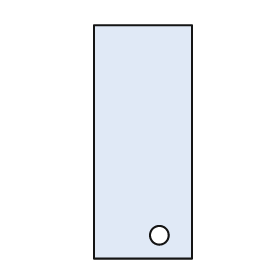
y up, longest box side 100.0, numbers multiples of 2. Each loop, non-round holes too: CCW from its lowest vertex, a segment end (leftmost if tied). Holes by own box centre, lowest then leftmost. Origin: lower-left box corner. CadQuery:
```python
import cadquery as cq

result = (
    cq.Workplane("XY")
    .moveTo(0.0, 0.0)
    .lineTo(42.0, 0.0)
    .lineTo(42.0, 100.0)
    .lineTo(0.0, 100.0)
    .close()
    .moveTo(28.0, 10.0)
    .circle(4.0)
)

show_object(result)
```